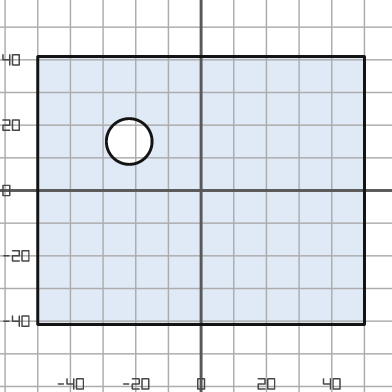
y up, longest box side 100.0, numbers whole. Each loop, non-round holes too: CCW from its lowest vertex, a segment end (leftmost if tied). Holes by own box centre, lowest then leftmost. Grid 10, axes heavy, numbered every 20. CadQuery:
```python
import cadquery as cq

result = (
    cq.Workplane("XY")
    .moveTo(-50.0, -41.0)
    .lineTo(50.0, -41.0)
    .lineTo(50.0, 41.0)
    .lineTo(-50.0, 41.0)
    .close()
    .moveTo(-22.0, 15.0)
    .circle(7.0)
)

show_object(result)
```